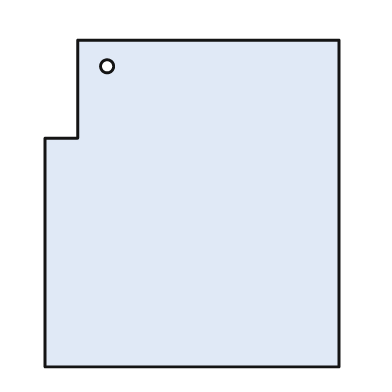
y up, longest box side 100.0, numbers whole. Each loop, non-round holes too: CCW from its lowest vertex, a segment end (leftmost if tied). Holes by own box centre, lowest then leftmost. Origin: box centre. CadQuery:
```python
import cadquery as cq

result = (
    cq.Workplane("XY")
    .moveTo(-45.0, -50.0)
    .lineTo(45.0, -50.0)
    .lineTo(45.0, 50.0)
    .lineTo(-35.0, 50.0)
    .lineTo(-35.0, 20.0)
    .lineTo(-45.0, 20.0)
    .close()
    .moveTo(-26.0, 42.0)
    .circle(2.0)
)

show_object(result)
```